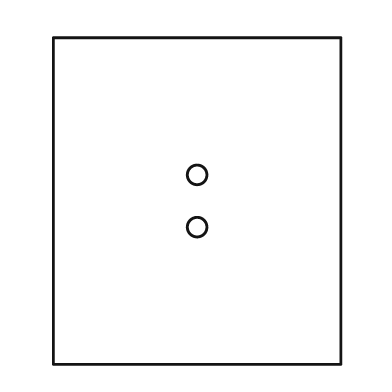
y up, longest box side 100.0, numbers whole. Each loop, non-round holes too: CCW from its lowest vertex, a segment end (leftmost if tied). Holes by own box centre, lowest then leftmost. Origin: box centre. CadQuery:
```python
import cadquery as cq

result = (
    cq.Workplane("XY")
    .moveTo(-44.0, -50.0)
    .lineTo(44.0, -50.0)
    .lineTo(44.0, 50.0)
    .lineTo(-44.0, 50.0)
    .close()
    .moveTo(0.0, -8.0)
    .circle(3.0)
    .moveTo(0.0, 8.0)
    .circle(3.0)
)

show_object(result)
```